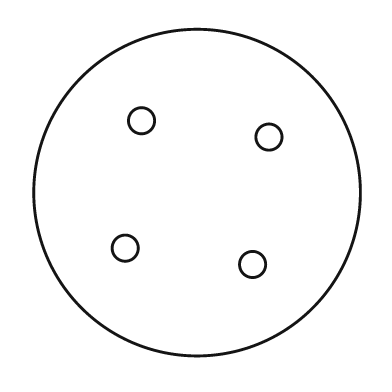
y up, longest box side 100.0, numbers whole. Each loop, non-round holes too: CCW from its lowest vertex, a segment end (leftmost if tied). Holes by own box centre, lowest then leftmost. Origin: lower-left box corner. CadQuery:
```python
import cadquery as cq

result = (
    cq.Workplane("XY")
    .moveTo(50.0, 50.0)
    .circle(50.0)
    .moveTo(67.0, 28.0)
    .circle(4.0)
    .moveTo(28.0, 33.0)
    .circle(4.0)
    .moveTo(72.0, 67.0)
    .circle(4.0)
    .moveTo(33.0, 72.0)
    .circle(4.0)
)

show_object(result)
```